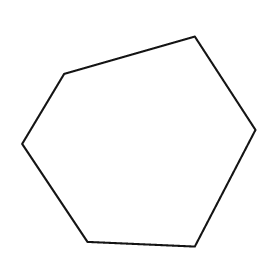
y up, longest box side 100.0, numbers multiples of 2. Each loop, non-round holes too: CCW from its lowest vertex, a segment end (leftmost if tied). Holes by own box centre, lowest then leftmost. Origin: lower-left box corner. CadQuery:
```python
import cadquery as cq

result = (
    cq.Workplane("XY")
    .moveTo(74.0, 0.0)
    .lineTo(100.0, 50.0)
    .lineTo(74.0, 90.0)
    .lineTo(18.0, 74.0)
    .lineTo(0.0, 44.0)
    .lineTo(28.0, 2.0)
    .close()
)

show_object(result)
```